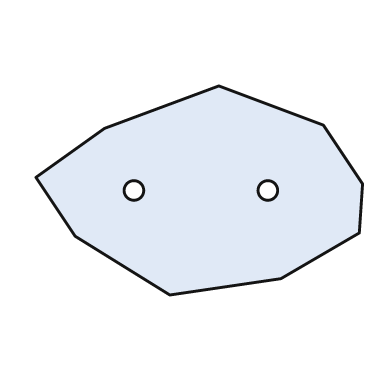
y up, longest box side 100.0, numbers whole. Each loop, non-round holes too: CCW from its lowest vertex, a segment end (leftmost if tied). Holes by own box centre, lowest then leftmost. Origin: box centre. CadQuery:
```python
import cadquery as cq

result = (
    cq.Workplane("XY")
    .moveTo(-9.0, -32.0)
    .lineTo(25.0, -27.0)
    .lineTo(49.0, -13.0)
    .lineTo(50.0, 2.0)
    .lineTo(38.0, 20.0)
    .lineTo(6.0, 32.0)
    .lineTo(-29.0, 19.0)
    .lineTo(-50.0, 4.0)
    .lineTo(-38.0, -14.0)
    .close()
    .moveTo(-20.0, 0.0)
    .circle(3.0)
    .moveTo(21.0, 0.0)
    .circle(3.0)
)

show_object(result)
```